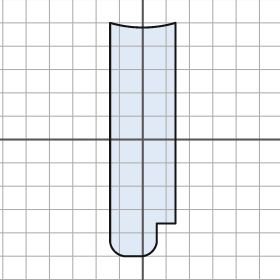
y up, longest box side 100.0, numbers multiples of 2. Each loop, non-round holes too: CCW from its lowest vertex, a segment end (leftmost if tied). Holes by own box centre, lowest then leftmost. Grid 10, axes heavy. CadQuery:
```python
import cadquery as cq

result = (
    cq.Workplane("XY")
    .moveTo(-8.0, -50.0)
    .lineTo(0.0, -50.0)
    .threePointArc((4.0, -48.0), (6.0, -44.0))
    .lineTo(6.0, -36.0)
    .lineTo(14.0, -36.0)
    .lineTo(14.0, 50.0)
    .threePointArc((0.0, 48.0), (-14.0, 50.0))
    .lineTo(-14.0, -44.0)
    .threePointArc((-12.0, -48.0), (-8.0, -50.0))
    .close()
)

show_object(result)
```